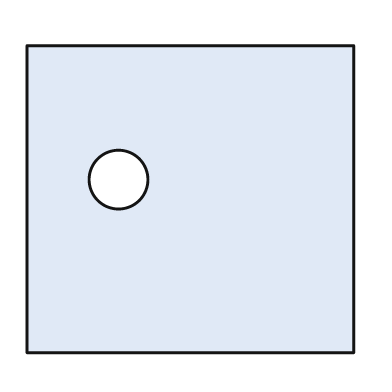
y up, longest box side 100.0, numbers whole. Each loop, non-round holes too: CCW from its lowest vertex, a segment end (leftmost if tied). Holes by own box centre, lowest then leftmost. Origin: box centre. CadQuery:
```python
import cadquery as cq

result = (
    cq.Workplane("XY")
    .moveTo(-50.0, -47.0)
    .lineTo(50.0, -47.0)
    .lineTo(50.0, 47.0)
    .lineTo(-50.0, 47.0)
    .close()
    .moveTo(-22.0, 6.0)
    .circle(9.0)
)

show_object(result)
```